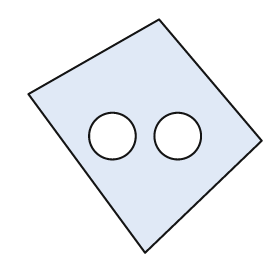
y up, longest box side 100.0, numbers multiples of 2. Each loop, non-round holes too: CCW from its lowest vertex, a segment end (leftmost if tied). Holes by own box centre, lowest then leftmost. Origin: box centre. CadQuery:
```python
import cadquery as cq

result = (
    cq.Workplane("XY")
    .moveTo(0.0, -50.0)
    .lineTo(50.0, -2.0)
    .lineTo(6.0, 50.0)
    .lineTo(-50.0, 18.0)
    .close()
    .moveTo(-14.0, 0.0)
    .circle(10.0)
    .moveTo(14.0, 0.0)
    .circle(10.0)
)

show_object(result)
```